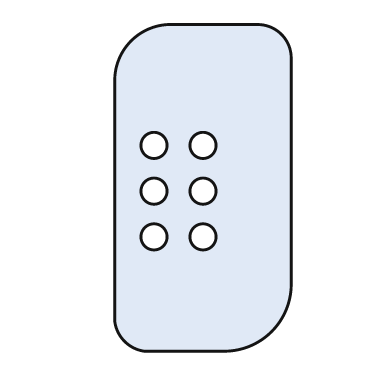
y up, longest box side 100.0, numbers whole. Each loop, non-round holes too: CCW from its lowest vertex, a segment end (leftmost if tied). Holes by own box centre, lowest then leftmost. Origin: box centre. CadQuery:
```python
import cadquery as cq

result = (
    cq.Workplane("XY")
    .moveTo(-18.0, -50.0)
    .lineTo(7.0, -50.0)
    .threePointArc((21.0, -44.0), (27.0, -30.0))
    .lineTo(27.0, 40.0)
    .threePointArc((24.0, 47.0), (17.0, 50.0))
    .lineTo(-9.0, 50.0)
    .threePointArc((-22.0, 45.0), (-27.0, 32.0))
    .lineTo(-27.0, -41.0)
    .threePointArc((-24.0, -47.0), (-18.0, -50.0))
    .close()
    .moveTo(-15.0, -15.0)
    .circle(4.0)
    .moveTo(0.0, -15.0)
    .circle(4.0)
    .moveTo(-15.0, -1.0)
    .circle(4.0)
    .moveTo(0.0, -1.0)
    .circle(4.0)
    .moveTo(-15.0, 13.0)
    .circle(4.0)
    .moveTo(0.0, 13.0)
    .circle(4.0)
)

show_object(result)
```